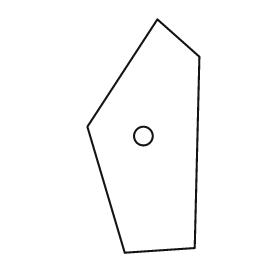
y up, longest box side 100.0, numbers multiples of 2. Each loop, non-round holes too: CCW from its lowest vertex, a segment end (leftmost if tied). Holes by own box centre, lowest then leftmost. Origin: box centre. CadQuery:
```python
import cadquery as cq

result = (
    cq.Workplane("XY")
    .moveTo(-8.0, -50.0)
    .lineTo(22.0, -48.0)
    .lineTo(24.0, 34.0)
    .lineTo(6.0, 50.0)
    .lineTo(-24.0, 4.0)
    .close()
    .moveTo(0.0, 0.0)
    .circle(4.0)
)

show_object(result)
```